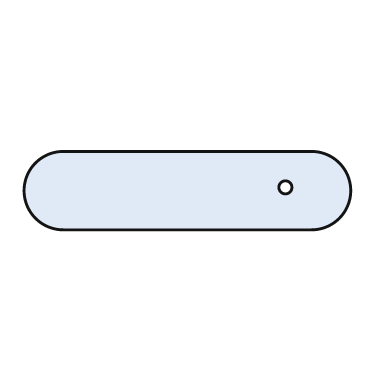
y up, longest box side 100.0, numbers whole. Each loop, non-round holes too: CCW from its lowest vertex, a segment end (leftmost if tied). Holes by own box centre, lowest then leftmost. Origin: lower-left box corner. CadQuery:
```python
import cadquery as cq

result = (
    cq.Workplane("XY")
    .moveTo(12.0, 0.0)
    .lineTo(88.0, 0.0)
    .threePointArc((100.0, 12.0), (88.0, 24.0))
    .lineTo(12.0, 24.0)
    .threePointArc((0.0, 12.0), (12.0, 0.0))
    .close()
    .moveTo(80.0, 13.0)
    .circle(2.0)
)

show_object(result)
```